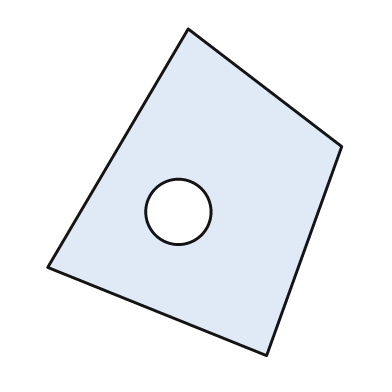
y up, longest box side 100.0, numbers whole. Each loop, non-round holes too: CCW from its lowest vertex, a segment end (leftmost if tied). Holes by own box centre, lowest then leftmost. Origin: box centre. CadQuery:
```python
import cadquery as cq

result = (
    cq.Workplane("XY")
    .moveTo(22.0, -50.0)
    .lineTo(45.0, 14.0)
    .lineTo(-2.0, 50.0)
    .lineTo(-45.0, -23.0)
    .close()
    .moveTo(-5.0, -6.0)
    .circle(10.0)
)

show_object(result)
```